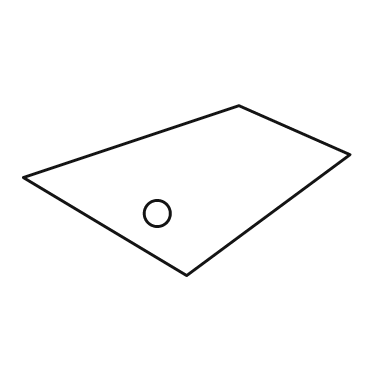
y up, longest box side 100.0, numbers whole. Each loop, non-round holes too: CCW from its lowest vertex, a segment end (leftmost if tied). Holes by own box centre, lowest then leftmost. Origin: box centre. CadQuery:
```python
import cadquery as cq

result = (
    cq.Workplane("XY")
    .moveTo(0.0, -26.0)
    .lineTo(50.0, 11.0)
    .lineTo(16.0, 26.0)
    .lineTo(-50.0, 4.0)
    .close()
    .moveTo(-9.0, -7.0)
    .circle(4.0)
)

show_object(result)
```